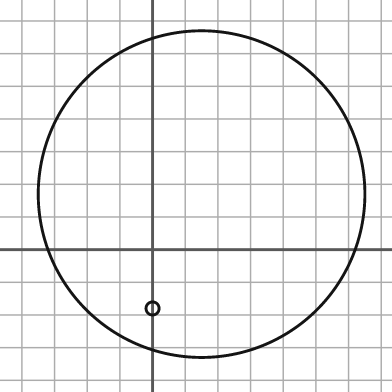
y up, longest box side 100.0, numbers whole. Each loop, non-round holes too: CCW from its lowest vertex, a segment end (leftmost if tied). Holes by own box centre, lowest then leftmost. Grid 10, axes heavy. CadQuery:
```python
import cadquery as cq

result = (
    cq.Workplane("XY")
    .moveTo(15.0, 17.0)
    .circle(50.0)
    .moveTo(0.0, -18.0)
    .circle(2.0)
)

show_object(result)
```